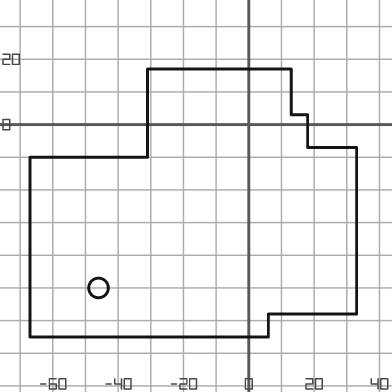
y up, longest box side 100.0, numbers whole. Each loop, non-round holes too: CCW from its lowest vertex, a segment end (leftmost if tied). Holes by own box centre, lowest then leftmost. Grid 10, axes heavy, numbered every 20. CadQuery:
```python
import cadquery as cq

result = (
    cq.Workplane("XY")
    .moveTo(-67.0, -65.0)
    .lineTo(6.0, -65.0)
    .lineTo(6.0, -58.0)
    .lineTo(33.0, -58.0)
    .lineTo(33.0, -7.0)
    .lineTo(18.0, -7.0)
    .lineTo(18.0, 3.0)
    .lineTo(13.0, 3.0)
    .lineTo(13.0, 17.0)
    .lineTo(-31.0, 17.0)
    .lineTo(-31.0, -10.0)
    .lineTo(-67.0, -10.0)
    .close()
    .moveTo(-46.0, -50.0)
    .circle(3.0)
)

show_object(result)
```